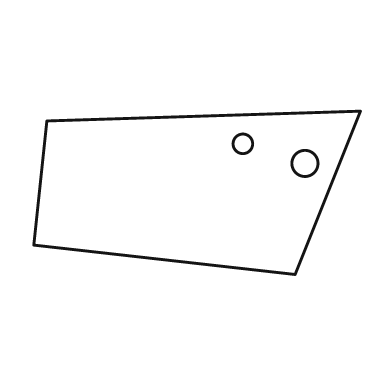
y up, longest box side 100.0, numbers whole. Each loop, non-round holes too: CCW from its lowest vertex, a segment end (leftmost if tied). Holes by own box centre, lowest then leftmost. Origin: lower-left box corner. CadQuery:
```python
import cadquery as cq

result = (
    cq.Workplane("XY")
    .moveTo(80.0, 0.0)
    .lineTo(100.0, 50.0)
    .lineTo(4.0, 47.0)
    .lineTo(0.0, 9.0)
    .close()
    .moveTo(83.0, 34.0)
    .circle(4.0)
    .moveTo(64.0, 40.0)
    .circle(3.0)
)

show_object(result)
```